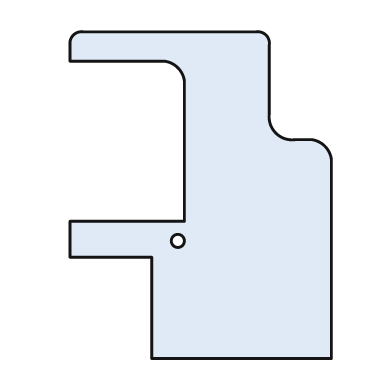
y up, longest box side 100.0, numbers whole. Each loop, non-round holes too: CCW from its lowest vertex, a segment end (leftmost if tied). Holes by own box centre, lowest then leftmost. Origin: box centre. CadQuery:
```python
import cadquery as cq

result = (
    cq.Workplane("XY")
    .moveTo(-15.0, -50.0)
    .lineTo(40.0, -50.0)
    .lineTo(40.0, 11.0)
    .threePointArc((38.0, 15.0), (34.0, 17.0))
    .lineTo(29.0, 17.0)
    .threePointArc((23.0, 19.0), (21.0, 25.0))
    .lineTo(21.0, 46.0)
    .threePointArc((20.0, 49.0), (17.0, 50.0))
    .lineTo(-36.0, 50.0)
    .threePointArc((-39.0, 49.0), (-40.0, 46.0))
    .lineTo(-40.0, 41.0)
    .lineTo(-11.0, 41.0)
    .threePointArc((-7.0, 39.0), (-5.0, 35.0))
    .lineTo(-5.0, -8.0)
    .lineTo(-40.0, -8.0)
    .lineTo(-40.0, -19.0)
    .lineTo(-15.0, -19.0)
    .close()
    .moveTo(-7.0, -14.0)
    .circle(2.0)
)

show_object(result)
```